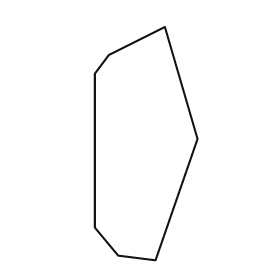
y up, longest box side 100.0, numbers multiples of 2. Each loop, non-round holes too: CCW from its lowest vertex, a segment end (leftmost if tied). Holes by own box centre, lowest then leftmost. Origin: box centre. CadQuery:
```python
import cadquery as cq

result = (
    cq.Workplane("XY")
    .moveTo(4.0, -50.0)
    .lineTo(22.0, 2.0)
    .lineTo(8.0, 50.0)
    .lineTo(-16.0, 38.0)
    .lineTo(-22.0, 30.0)
    .lineTo(-22.0, -36.0)
    .lineTo(-12.0, -48.0)
    .close()
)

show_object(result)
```